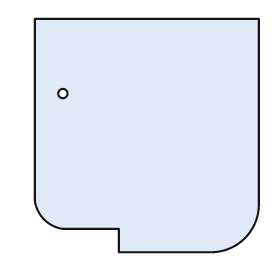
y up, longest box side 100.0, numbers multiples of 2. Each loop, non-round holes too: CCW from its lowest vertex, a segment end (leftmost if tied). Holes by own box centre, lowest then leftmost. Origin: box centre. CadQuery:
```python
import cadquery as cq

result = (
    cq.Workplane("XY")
    .moveTo(-12.0, -50.0)
    .lineTo(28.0, -50.0)
    .threePointArc((42.0, -44.0), (48.0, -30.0))
    .lineTo(48.0, 50.0)
    .lineTo(-48.0, 50.0)
    .lineTo(-48.0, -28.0)
    .threePointArc((-44.0, -36.0), (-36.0, -40.0))
    .lineTo(-12.0, -40.0)
    .close()
    .moveTo(-36.0, 18.0)
    .circle(2.0)
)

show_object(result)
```